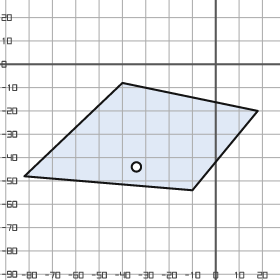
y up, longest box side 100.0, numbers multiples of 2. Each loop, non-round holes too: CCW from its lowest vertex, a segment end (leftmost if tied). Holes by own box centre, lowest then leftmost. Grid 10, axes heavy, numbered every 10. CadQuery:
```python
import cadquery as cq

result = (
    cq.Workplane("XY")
    .moveTo(-10.0, -54.0)
    .lineTo(18.0, -20.0)
    .lineTo(-40.0, -8.0)
    .lineTo(-82.0, -48.0)
    .close()
    .moveTo(-34.0, -44.0)
    .circle(2.0)
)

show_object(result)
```